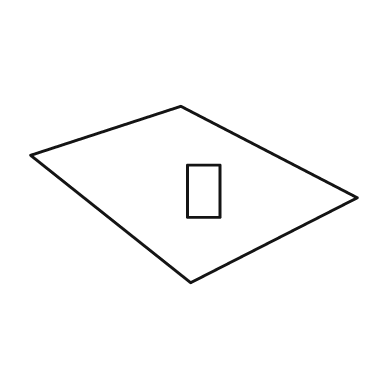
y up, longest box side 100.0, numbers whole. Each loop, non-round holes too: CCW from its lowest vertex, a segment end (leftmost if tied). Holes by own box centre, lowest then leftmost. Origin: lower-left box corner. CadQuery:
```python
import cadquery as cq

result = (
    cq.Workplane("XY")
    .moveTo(49.0, 0.0)
    .lineTo(100.0, 26.0)
    .lineTo(46.0, 54.0)
    .lineTo(0.0, 39.0)
    .close()
    .moveTo(48.0, 20.0)
    .lineTo(58.0, 20.0)
    .lineTo(58.0, 36.0)
    .lineTo(48.0, 36.0)
    .close()
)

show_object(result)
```